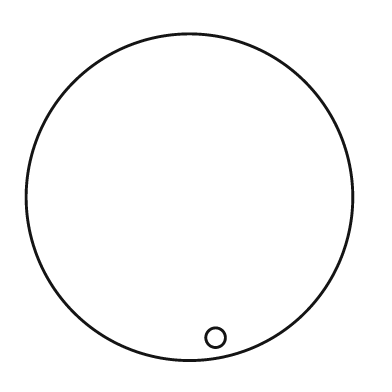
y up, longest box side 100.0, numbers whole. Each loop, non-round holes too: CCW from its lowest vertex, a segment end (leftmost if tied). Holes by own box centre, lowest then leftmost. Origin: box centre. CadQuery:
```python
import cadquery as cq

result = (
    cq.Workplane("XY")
    .moveTo(0.0, 0.0)
    .circle(50.0)
    .moveTo(8.0, -43.0)
    .circle(3.0)
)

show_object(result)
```